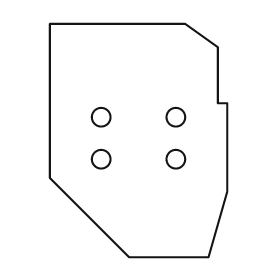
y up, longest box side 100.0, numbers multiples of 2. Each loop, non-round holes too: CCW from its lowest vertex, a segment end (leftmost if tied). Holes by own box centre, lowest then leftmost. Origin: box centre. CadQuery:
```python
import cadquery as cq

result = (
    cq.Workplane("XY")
    .moveTo(-4.0, -50.0)
    .lineTo(30.0, -50.0)
    .lineTo(38.0, -22.0)
    .lineTo(38.0, 16.0)
    .lineTo(34.0, 16.0)
    .lineTo(34.0, 40.0)
    .lineTo(20.0, 50.0)
    .lineTo(-38.0, 50.0)
    .lineTo(-38.0, -16.0)
    .close()
    .moveTo(-16.0, -8.0)
    .circle(4.0)
    .moveTo(16.0, -8.0)
    .circle(4.0)
    .moveTo(-16.0, 10.0)
    .circle(4.0)
    .moveTo(16.0, 10.0)
    .circle(4.0)
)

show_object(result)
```